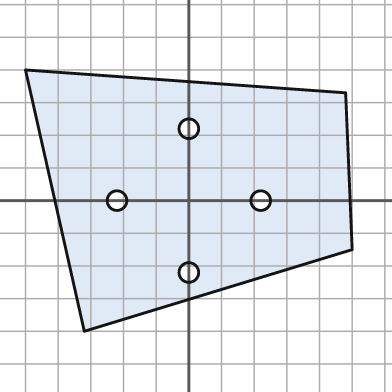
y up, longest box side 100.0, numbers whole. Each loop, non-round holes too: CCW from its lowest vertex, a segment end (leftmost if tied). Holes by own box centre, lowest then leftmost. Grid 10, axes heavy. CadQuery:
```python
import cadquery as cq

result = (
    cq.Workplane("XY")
    .moveTo(-32.0, -40.0)
    .lineTo(50.0, -15.0)
    .lineTo(48.0, 33.0)
    .lineTo(-50.0, 40.0)
    .close()
    .moveTo(0.0, -22.0)
    .circle(3.0)
    .moveTo(-22.0, 0.0)
    .circle(3.0)
    .moveTo(22.0, 0.0)
    .circle(3.0)
    .moveTo(0.0, 22.0)
    .circle(3.0)
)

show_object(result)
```